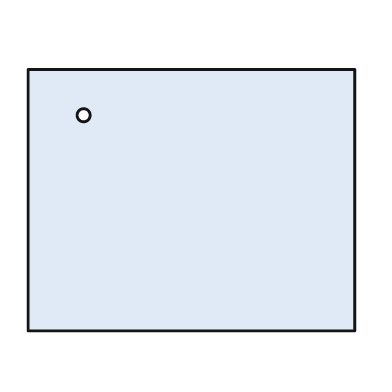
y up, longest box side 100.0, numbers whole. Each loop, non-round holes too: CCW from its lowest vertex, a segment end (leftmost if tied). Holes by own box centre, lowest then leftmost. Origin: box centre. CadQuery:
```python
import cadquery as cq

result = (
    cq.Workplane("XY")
    .moveTo(-50.0, -40.0)
    .lineTo(50.0, -40.0)
    .lineTo(50.0, 40.0)
    .lineTo(-50.0, 40.0)
    .close()
    .moveTo(-33.0, 26.0)
    .circle(2.0)
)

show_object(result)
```